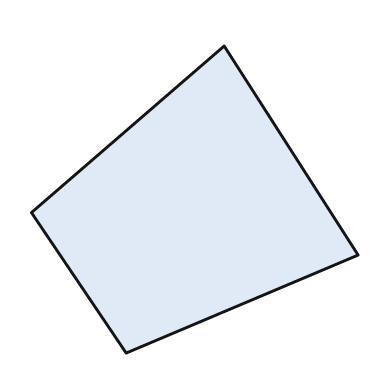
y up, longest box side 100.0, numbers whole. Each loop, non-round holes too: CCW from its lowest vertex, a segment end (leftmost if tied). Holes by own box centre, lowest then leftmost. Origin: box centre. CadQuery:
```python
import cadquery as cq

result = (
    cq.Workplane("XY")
    .moveTo(-21.0, -47.0)
    .lineTo(50.0, -17.0)
    .lineTo(9.0, 47.0)
    .lineTo(-50.0, -4.0)
    .close()
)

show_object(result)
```